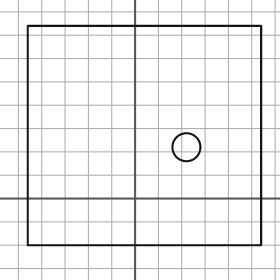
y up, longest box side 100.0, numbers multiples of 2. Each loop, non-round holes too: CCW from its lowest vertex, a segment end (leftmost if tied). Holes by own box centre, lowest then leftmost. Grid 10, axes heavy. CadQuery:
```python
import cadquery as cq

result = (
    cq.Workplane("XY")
    .moveTo(-46.0, -20.0)
    .lineTo(54.0, -20.0)
    .lineTo(54.0, 74.0)
    .lineTo(-46.0, 74.0)
    .close()
    .moveTo(22.0, 22.0)
    .circle(6.0)
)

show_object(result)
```